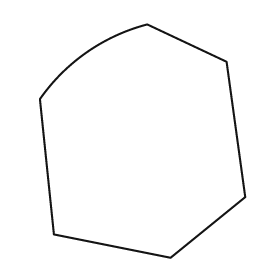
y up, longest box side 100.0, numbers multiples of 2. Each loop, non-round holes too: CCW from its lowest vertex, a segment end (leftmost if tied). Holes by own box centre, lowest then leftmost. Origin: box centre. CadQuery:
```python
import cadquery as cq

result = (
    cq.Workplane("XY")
    .moveTo(12.0, -50.0)
    .lineTo(44.0, -24.0)
    .lineTo(36.0, 34.0)
    .lineTo(2.0, 50.0)
    .threePointArc((-24.0, 38.0), (-44.0, 18.0))
    .lineTo(-38.0, -40.0)
    .close()
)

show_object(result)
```